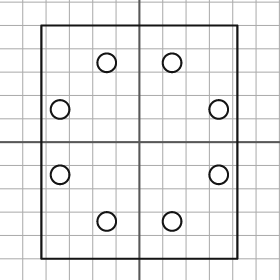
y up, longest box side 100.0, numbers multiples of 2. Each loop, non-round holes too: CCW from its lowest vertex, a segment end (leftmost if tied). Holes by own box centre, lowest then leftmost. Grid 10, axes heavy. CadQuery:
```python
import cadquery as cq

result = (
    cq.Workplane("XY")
    .moveTo(-42.0, -50.0)
    .lineTo(42.0, -50.0)
    .lineTo(42.0, 50.0)
    .lineTo(-42.0, 50.0)
    .close()
    .moveTo(-14.0, -34.0)
    .circle(4.0)
    .moveTo(14.0, -34.0)
    .circle(4.0)
    .moveTo(-34.0, -14.0)
    .circle(4.0)
    .moveTo(34.0, -14.0)
    .circle(4.0)
    .moveTo(-34.0, 14.0)
    .circle(4.0)
    .moveTo(34.0, 14.0)
    .circle(4.0)
    .moveTo(-14.0, 34.0)
    .circle(4.0)
    .moveTo(14.0, 34.0)
    .circle(4.0)
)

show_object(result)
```